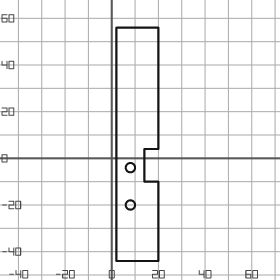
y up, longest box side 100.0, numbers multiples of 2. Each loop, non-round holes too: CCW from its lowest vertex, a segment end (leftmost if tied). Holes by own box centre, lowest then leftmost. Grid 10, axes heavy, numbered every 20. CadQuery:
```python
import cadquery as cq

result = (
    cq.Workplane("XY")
    .moveTo(2.0, -44.0)
    .lineTo(20.0, -44.0)
    .lineTo(20.0, -10.0)
    .lineTo(14.0, -10.0)
    .lineTo(14.0, 4.0)
    .lineTo(20.0, 4.0)
    .lineTo(20.0, 56.0)
    .lineTo(2.0, 56.0)
    .close()
    .moveTo(8.0, -20.0)
    .circle(2.0)
    .moveTo(8.0, -4.0)
    .circle(2.0)
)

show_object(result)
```